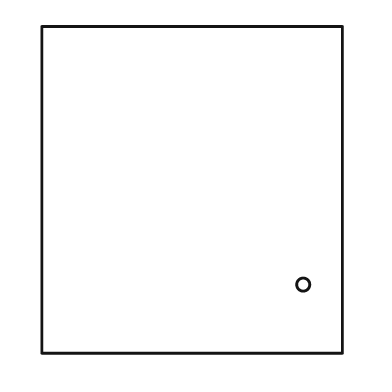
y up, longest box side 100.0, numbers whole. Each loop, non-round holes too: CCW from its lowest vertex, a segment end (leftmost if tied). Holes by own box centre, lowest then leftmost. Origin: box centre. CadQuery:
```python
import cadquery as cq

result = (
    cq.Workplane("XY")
    .moveTo(-46.0, -50.0)
    .lineTo(46.0, -50.0)
    .lineTo(46.0, 50.0)
    .lineTo(-46.0, 50.0)
    .close()
    .moveTo(34.0, -29.0)
    .circle(2.0)
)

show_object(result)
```